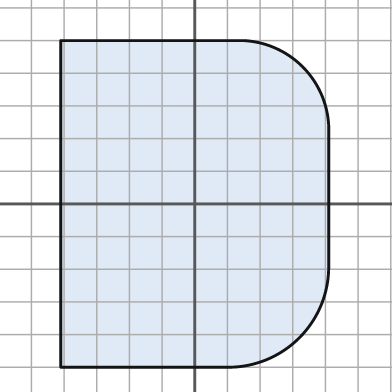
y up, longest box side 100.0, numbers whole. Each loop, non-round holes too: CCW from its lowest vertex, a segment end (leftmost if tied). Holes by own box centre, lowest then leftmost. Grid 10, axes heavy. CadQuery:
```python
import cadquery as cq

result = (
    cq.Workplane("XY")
    .moveTo(-41.0, -50.0)
    .lineTo(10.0, -50.0)
    .threePointArc((32.0, -41.0), (41.0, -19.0))
    .lineTo(41.0, 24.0)
    .threePointArc((33.0, 42.0), (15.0, 50.0))
    .lineTo(-41.0, 50.0)
    .close()
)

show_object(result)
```